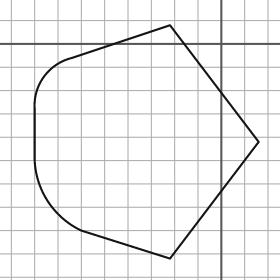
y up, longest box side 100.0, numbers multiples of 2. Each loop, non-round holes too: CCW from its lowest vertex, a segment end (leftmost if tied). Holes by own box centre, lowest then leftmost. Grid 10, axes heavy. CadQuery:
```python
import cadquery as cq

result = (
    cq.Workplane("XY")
    .moveTo(-22.0, -92.0)
    .lineTo(16.0, -42.0)
    .lineTo(-22.0, 8.0)
    .lineTo(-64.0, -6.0)
    .threePointArc((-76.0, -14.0), (-80.0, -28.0))
    .lineTo(-80.0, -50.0)
    .threePointArc((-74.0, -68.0), (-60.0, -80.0))
    .close()
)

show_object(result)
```